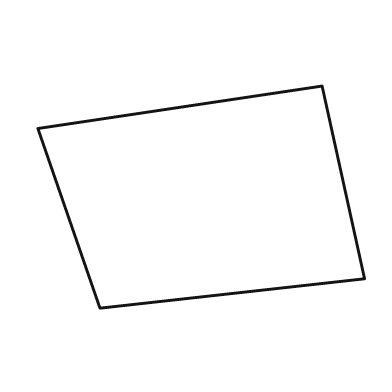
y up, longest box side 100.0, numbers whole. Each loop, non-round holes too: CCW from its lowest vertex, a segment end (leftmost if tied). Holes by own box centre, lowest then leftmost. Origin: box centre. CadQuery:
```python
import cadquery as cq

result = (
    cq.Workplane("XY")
    .moveTo(-31.0, -34.0)
    .lineTo(50.0, -25.0)
    .lineTo(37.0, 34.0)
    .lineTo(-50.0, 21.0)
    .close()
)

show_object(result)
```